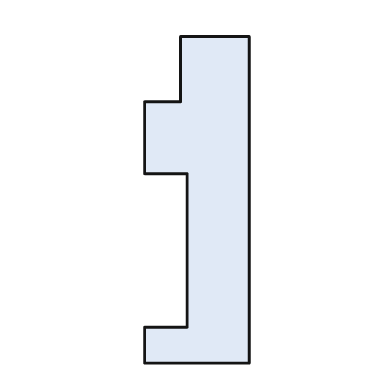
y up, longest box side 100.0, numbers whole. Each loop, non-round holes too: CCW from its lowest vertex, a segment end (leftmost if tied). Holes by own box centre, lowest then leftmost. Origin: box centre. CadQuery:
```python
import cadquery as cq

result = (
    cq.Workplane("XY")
    .moveTo(-16.0, -50.0)
    .lineTo(16.0, -50.0)
    .lineTo(16.0, 50.0)
    .lineTo(-5.0, 50.0)
    .lineTo(-5.0, 30.0)
    .lineTo(-16.0, 30.0)
    .lineTo(-16.0, 8.0)
    .lineTo(-3.0, 8.0)
    .lineTo(-3.0, -39.0)
    .lineTo(-16.0, -39.0)
    .close()
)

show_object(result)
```